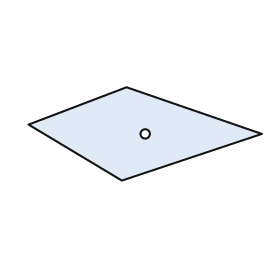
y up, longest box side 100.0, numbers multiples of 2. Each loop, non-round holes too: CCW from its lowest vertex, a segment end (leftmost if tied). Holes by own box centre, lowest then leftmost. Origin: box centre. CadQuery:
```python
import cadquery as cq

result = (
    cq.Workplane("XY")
    .moveTo(-10.0, -20.0)
    .lineTo(50.0, 0.0)
    .lineTo(-8.0, 20.0)
    .lineTo(-50.0, 4.0)
    .close()
    .moveTo(0.0, 0.0)
    .circle(2.0)
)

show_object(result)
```